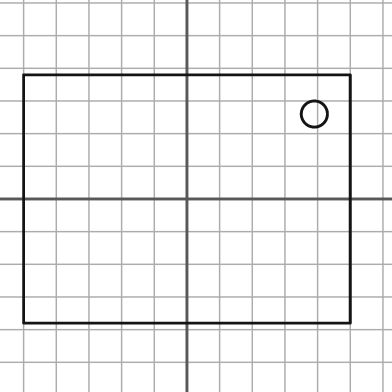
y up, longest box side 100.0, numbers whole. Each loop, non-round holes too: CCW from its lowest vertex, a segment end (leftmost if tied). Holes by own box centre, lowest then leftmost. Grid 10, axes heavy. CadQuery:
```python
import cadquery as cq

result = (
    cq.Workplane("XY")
    .moveTo(-50.0, -38.0)
    .lineTo(50.0, -38.0)
    .lineTo(50.0, 38.0)
    .lineTo(-50.0, 38.0)
    .close()
    .moveTo(39.0, 26.0)
    .circle(4.0)
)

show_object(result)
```